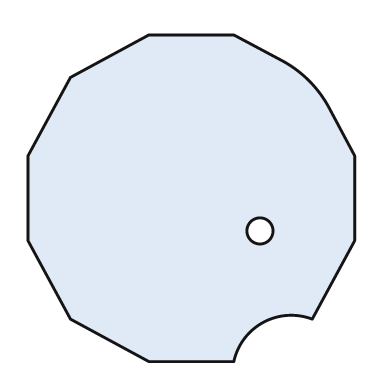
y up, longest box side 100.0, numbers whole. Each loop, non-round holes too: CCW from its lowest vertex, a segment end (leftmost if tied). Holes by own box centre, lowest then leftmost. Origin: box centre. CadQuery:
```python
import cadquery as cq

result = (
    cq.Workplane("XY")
    .moveTo(-13.0, -50.0)
    .lineTo(13.0, -50.0)
    .threePointArc((22.0, -38.0), (37.0, -37.0))
    .lineTo(50.0, -13.0)
    .lineTo(50.0, 13.0)
    .lineTo(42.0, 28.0)
    .threePointArc((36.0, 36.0), (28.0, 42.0))
    .lineTo(13.0, 50.0)
    .lineTo(-13.0, 50.0)
    .lineTo(-37.0, 37.0)
    .lineTo(-50.0, 13.0)
    .lineTo(-50.0, -13.0)
    .lineTo(-37.0, -37.0)
    .close()
    .moveTo(21.0, -10.0)
    .circle(4.0)
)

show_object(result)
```